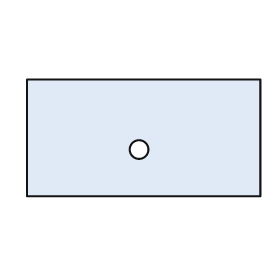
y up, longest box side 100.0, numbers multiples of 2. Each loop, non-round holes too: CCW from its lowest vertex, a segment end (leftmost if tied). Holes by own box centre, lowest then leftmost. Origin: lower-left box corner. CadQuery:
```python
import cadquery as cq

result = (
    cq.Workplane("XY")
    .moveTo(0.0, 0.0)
    .lineTo(100.0, 0.0)
    .lineTo(100.0, 50.0)
    .lineTo(0.0, 50.0)
    .close()
    .moveTo(48.0, 20.0)
    .circle(4.0)
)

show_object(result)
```